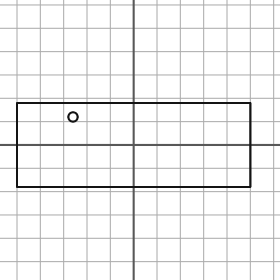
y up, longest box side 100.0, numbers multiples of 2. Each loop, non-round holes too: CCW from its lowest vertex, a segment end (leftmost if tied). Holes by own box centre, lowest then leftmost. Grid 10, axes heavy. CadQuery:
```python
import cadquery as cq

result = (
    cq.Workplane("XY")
    .moveTo(-50.0, -18.0)
    .lineTo(50.0, -18.0)
    .lineTo(50.0, 18.0)
    .lineTo(-50.0, 18.0)
    .close()
    .moveTo(-26.0, 12.0)
    .circle(2.0)
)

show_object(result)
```